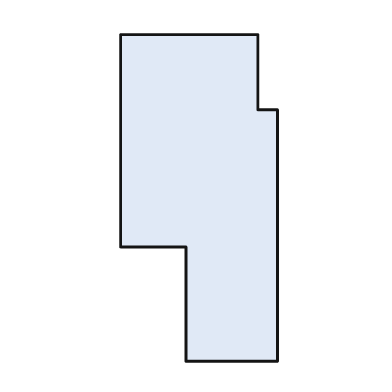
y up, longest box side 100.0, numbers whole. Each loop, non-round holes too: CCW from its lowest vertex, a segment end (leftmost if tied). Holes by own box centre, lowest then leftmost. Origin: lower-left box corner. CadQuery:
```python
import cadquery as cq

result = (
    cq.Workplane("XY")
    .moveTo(20.0, 0.0)
    .lineTo(48.0, 0.0)
    .lineTo(48.0, 77.0)
    .lineTo(42.0, 77.0)
    .lineTo(42.0, 100.0)
    .lineTo(0.0, 100.0)
    .lineTo(0.0, 35.0)
    .lineTo(20.0, 35.0)
    .close()
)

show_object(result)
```